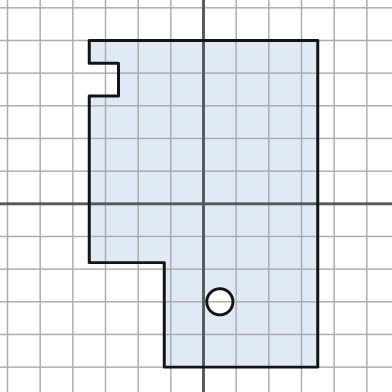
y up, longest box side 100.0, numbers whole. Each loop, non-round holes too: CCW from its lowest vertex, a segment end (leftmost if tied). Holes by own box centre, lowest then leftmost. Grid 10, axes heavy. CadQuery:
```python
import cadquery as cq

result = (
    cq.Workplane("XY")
    .moveTo(-12.0, -50.0)
    .lineTo(35.0, -50.0)
    .lineTo(35.0, 50.0)
    .lineTo(-35.0, 50.0)
    .lineTo(-35.0, 43.0)
    .lineTo(-26.0, 43.0)
    .lineTo(-26.0, 33.0)
    .lineTo(-35.0, 33.0)
    .lineTo(-35.0, -18.0)
    .lineTo(-12.0, -18.0)
    .close()
    .moveTo(5.0, -30.0)
    .circle(4.0)
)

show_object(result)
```